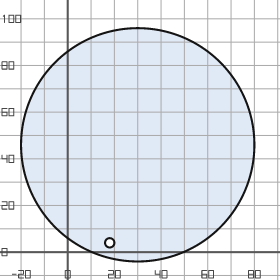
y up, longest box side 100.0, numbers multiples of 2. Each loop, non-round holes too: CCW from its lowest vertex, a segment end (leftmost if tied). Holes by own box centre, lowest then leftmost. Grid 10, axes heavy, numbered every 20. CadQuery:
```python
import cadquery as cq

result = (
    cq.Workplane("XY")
    .moveTo(30.0, 46.0)
    .circle(50.0)
    .moveTo(18.0, 4.0)
    .circle(2.0)
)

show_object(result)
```